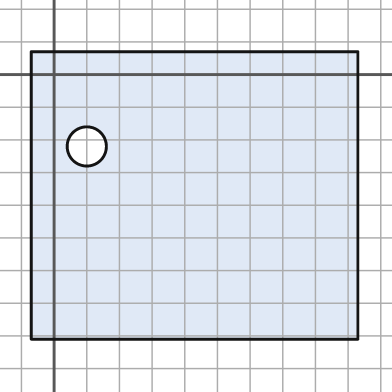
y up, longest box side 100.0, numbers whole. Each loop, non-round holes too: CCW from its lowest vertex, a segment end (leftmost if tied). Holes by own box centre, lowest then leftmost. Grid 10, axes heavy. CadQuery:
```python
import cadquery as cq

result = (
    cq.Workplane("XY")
    .moveTo(-7.0, -81.0)
    .lineTo(93.0, -81.0)
    .lineTo(93.0, 7.0)
    .lineTo(-7.0, 7.0)
    .close()
    .moveTo(10.0, -22.0)
    .circle(6.0)
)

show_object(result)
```